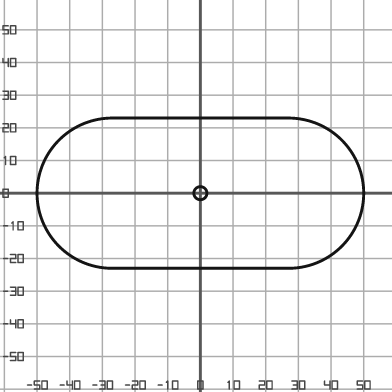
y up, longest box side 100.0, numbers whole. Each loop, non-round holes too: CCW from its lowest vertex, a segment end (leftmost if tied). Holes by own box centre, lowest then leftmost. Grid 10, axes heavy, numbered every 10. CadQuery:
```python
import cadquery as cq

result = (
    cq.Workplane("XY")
    .moveTo(-27.0, -23.0)
    .lineTo(27.0, -23.0)
    .threePointArc((50.0, 0.0), (27.0, 23.0))
    .lineTo(-27.0, 23.0)
    .threePointArc((-50.0, 0.0), (-27.0, -23.0))
    .close()
    .moveTo(0.0, 0.0)
    .circle(2.0)
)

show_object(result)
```